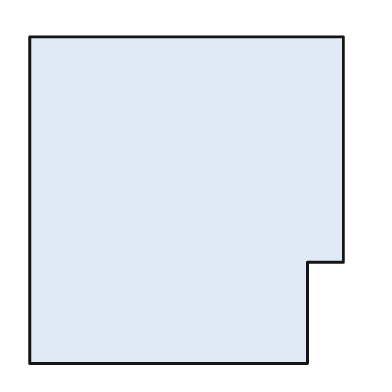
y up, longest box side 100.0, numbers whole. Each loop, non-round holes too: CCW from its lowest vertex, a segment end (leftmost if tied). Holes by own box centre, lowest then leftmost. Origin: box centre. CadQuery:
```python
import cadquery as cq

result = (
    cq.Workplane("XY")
    .moveTo(-48.0, -50.0)
    .lineTo(37.0, -50.0)
    .lineTo(37.0, -19.0)
    .lineTo(48.0, -19.0)
    .lineTo(48.0, 50.0)
    .lineTo(-48.0, 50.0)
    .close()
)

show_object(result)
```